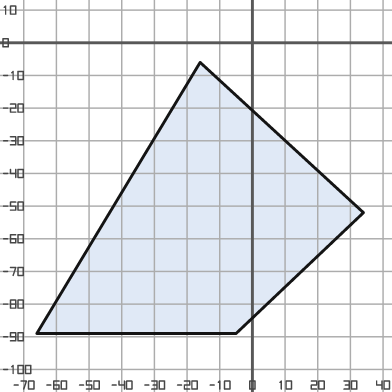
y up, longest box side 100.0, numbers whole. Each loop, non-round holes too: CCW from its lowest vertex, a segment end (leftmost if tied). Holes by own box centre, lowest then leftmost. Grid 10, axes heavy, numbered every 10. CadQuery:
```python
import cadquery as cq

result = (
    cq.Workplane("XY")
    .moveTo(-66.0, -89.0)
    .lineTo(-5.0, -89.0)
    .lineTo(34.0, -52.0)
    .lineTo(-16.0, -6.0)
    .close()
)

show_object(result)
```